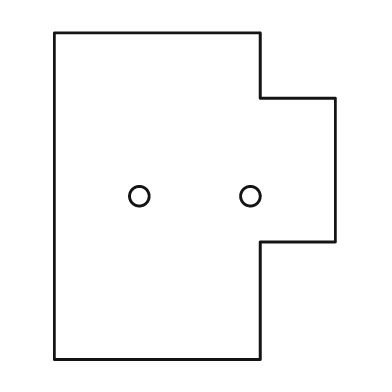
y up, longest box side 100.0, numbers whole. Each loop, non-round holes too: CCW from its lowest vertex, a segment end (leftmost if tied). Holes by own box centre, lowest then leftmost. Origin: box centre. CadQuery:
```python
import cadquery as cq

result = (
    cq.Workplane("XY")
    .moveTo(-43.0, -50.0)
    .lineTo(20.0, -50.0)
    .lineTo(20.0, -14.0)
    .lineTo(43.0, -14.0)
    .lineTo(43.0, 30.0)
    .lineTo(20.0, 30.0)
    .lineTo(20.0, 50.0)
    .lineTo(-43.0, 50.0)
    .close()
    .moveTo(-17.0, 0.0)
    .circle(3.0)
    .moveTo(17.0, 0.0)
    .circle(3.0)
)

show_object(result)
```